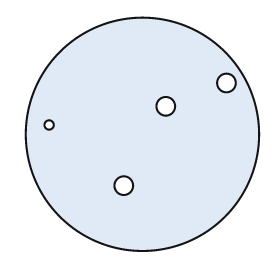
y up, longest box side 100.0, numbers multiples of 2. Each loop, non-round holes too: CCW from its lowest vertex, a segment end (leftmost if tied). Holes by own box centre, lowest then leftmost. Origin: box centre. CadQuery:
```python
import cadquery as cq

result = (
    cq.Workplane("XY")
    .moveTo(0.0, 0.0)
    .circle(50.0)
    .moveTo(-8.0, -22.0)
    .circle(4.0)
    .moveTo(-40.0, 4.0)
    .circle(2.0)
    .moveTo(10.0, 12.0)
    .circle(4.0)
    .moveTo(36.0, 22.0)
    .circle(4.0)
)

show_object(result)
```